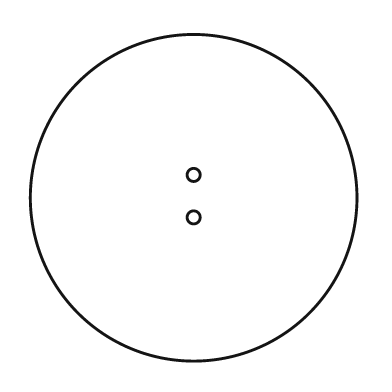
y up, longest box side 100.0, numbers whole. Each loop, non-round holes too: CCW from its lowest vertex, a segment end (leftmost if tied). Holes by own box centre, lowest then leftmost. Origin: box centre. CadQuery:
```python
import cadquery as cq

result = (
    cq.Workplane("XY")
    .moveTo(0.0, 0.0)
    .circle(50.0)
    .moveTo(0.0, -6.0)
    .circle(2.0)
    .moveTo(0.0, 7.0)
    .circle(2.0)
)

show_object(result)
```